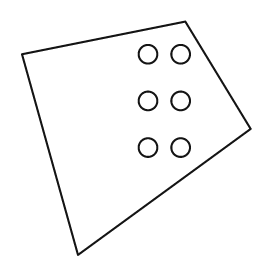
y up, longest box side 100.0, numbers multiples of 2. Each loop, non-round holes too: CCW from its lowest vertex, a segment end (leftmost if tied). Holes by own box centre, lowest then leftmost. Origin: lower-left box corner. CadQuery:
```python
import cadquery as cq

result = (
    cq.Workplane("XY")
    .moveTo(24.0, 0.0)
    .lineTo(98.0, 54.0)
    .lineTo(70.0, 100.0)
    .lineTo(0.0, 86.0)
    .close()
    .moveTo(54.0, 46.0)
    .circle(4.0)
    .moveTo(68.0, 46.0)
    .circle(4.0)
    .moveTo(54.0, 66.0)
    .circle(4.0)
    .moveTo(68.0, 66.0)
    .circle(4.0)
    .moveTo(54.0, 86.0)
    .circle(4.0)
    .moveTo(68.0, 86.0)
    .circle(4.0)
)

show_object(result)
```